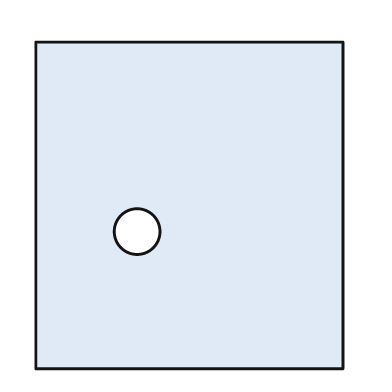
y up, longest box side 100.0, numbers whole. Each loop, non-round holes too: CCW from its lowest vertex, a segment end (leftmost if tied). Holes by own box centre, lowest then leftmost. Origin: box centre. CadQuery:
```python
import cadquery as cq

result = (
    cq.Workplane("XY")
    .moveTo(-47.0, -50.0)
    .lineTo(47.0, -50.0)
    .lineTo(47.0, 50.0)
    .lineTo(-47.0, 50.0)
    .close()
    .moveTo(-16.0, -8.0)
    .circle(7.0)
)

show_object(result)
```